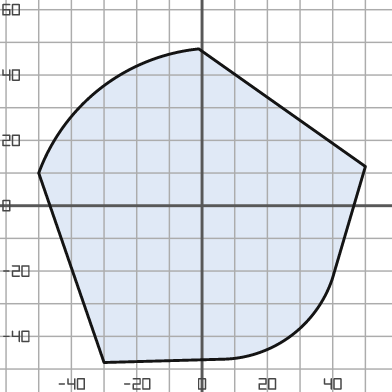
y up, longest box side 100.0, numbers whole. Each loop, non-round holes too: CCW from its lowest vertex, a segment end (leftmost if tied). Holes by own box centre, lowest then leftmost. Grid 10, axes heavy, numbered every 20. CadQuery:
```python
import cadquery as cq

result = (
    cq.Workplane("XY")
    .moveTo(-30.0, -48.0)
    .lineTo(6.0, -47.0)
    .threePointArc((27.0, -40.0), (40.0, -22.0))
    .lineTo(50.0, 12.0)
    .lineTo(-1.0, 48.0)
    .threePointArc((-31.0, 36.0), (-50.0, 10.0))
    .close()
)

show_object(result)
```